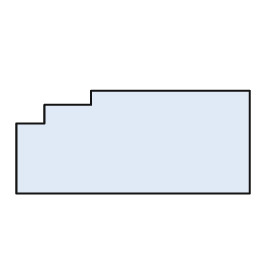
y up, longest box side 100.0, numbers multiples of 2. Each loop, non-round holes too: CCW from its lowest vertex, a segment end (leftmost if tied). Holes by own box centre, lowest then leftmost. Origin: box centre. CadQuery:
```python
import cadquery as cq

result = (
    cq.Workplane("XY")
    .moveTo(-50.0, -22.0)
    .lineTo(50.0, -22.0)
    .lineTo(50.0, 22.0)
    .lineTo(-18.0, 22.0)
    .lineTo(-18.0, 16.0)
    .lineTo(-38.0, 16.0)
    .lineTo(-38.0, 8.0)
    .lineTo(-50.0, 8.0)
    .close()
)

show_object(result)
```